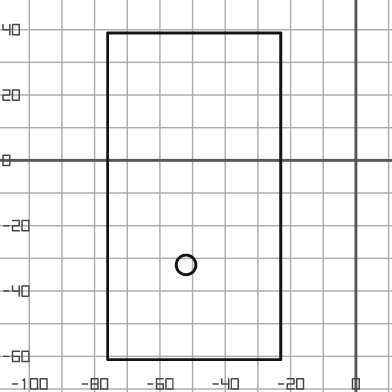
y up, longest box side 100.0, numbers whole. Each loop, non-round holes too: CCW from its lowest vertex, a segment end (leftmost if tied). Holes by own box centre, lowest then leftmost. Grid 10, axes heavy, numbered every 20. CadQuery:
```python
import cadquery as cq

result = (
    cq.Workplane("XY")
    .moveTo(-76.0, -61.0)
    .lineTo(-23.0, -61.0)
    .lineTo(-23.0, 39.0)
    .lineTo(-76.0, 39.0)
    .close()
    .moveTo(-52.0, -32.0)
    .circle(3.0)
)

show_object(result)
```